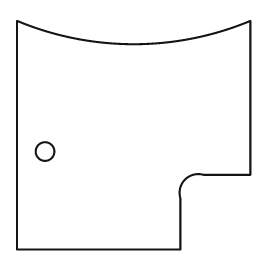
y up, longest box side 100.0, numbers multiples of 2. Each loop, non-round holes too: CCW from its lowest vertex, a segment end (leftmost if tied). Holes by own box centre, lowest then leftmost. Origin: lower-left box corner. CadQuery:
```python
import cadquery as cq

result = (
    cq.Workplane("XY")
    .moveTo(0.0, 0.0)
    .lineTo(70.0, 0.0)
    .lineTo(70.0, 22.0)
    .threePointArc((72.0, 30.0), (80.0, 32.0))
    .lineTo(100.0, 32.0)
    .lineTo(100.0, 98.0)
    .threePointArc((50.0, 88.0), (0.0, 98.0))
    .close()
    .moveTo(12.0, 42.0)
    .circle(4.0)
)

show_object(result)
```